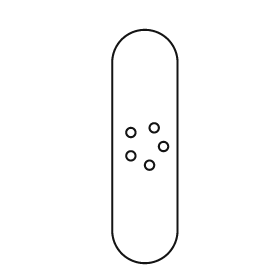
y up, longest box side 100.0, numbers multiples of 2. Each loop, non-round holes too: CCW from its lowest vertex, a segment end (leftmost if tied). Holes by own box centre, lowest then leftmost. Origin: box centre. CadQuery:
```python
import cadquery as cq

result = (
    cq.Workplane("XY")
    .moveTo(-14.0, -36.0)
    .threePointArc((0.0, -50.0), (14.0, -36.0))
    .lineTo(14.0, 36.0)
    .threePointArc((0.0, 50.0), (-14.0, 36.0))
    .close()
    .moveTo(2.0, -8.0)
    .circle(2.0)
    .moveTo(-6.0, -4.0)
    .circle(2.0)
    .moveTo(8.0, 0.0)
    .circle(2.0)
    .moveTo(-6.0, 6.0)
    .circle(2.0)
    .moveTo(4.0, 8.0)
    .circle(2.0)
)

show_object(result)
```